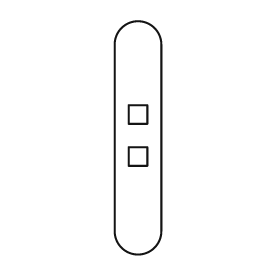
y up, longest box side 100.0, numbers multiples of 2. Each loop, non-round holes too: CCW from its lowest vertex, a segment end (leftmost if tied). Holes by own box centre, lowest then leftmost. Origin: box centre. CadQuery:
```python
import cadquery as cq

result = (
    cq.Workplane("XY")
    .moveTo(-10.0, -40.0)
    .threePointArc((0.0, -50.0), (10.0, -40.0))
    .lineTo(10.0, 40.0)
    .threePointArc((0.0, 50.0), (-10.0, 40.0))
    .close()
    .moveTo(-4.0, -12.0)
    .lineTo(4.0, -12.0)
    .lineTo(4.0, -4.0)
    .lineTo(-4.0, -4.0)
    .close()
    .moveTo(-4.0, 6.0)
    .lineTo(4.0, 6.0)
    .lineTo(4.0, 14.0)
    .lineTo(-4.0, 14.0)
    .close()
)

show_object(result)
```